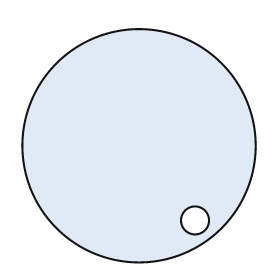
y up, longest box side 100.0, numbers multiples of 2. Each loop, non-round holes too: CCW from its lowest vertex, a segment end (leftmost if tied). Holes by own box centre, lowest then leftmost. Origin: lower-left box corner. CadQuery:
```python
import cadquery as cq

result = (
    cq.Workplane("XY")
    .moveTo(50.0, 50.0)
    .circle(50.0)
    .moveTo(74.0, 18.0)
    .circle(6.0)
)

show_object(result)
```